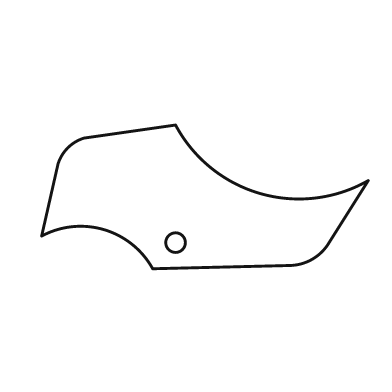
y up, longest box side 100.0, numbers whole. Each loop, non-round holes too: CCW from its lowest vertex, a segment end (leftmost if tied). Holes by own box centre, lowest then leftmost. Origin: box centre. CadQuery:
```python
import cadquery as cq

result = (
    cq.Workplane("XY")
    .moveTo(-16.0, -22.0)
    .lineTo(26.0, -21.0)
    .threePointArc((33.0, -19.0), (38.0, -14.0))
    .lineTo(50.0, 5.0)
    .threePointArc((17.0, 1.0), (-9.0, 22.0))
    .lineTo(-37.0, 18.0)
    .threePointArc((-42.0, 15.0), (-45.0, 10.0))
    .lineTo(-50.0, -12.0)
    .threePointArc((-31.0, -10.0), (-16.0, -22.0))
    .close()
    .moveTo(-9.0, -14.0)
    .circle(3.0)
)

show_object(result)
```